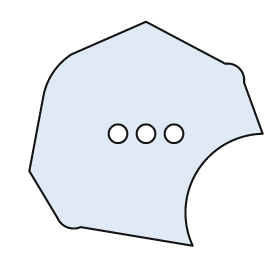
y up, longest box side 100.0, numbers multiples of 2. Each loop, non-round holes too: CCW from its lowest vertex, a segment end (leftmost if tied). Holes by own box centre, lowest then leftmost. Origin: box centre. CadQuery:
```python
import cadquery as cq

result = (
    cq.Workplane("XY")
    .moveTo(20.0, -48.0)
    .threePointArc((22.0, -16.0), (50.0, 0.0))
    .lineTo(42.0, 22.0)
    .threePointArc((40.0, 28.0), (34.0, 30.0))
    .lineTo(0.0, 48.0)
    .lineTo(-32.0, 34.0)
    .threePointArc((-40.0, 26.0), (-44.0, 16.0))
    .lineTo(-50.0, -16.0)
    .lineTo(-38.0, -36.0)
    .threePointArc((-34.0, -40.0), (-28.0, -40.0))
    .close()
    .moveTo(-12.0, 0.0)
    .circle(4.0)
    .moveTo(0.0, 0.0)
    .circle(4.0)
    .moveTo(12.0, 0.0)
    .circle(4.0)
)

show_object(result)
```